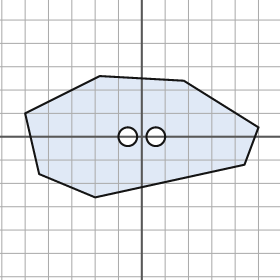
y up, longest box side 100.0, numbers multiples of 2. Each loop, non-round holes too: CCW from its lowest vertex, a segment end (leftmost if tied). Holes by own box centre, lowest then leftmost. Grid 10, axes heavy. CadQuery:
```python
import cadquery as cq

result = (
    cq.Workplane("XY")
    .moveTo(-20.0, -26.0)
    .lineTo(44.0, -12.0)
    .lineTo(50.0, 4.0)
    .lineTo(18.0, 24.0)
    .lineTo(-18.0, 26.0)
    .lineTo(-50.0, 10.0)
    .lineTo(-44.0, -16.0)
    .close()
    .moveTo(-6.0, 0.0)
    .circle(4.0)
    .moveTo(6.0, 0.0)
    .circle(4.0)
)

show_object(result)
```